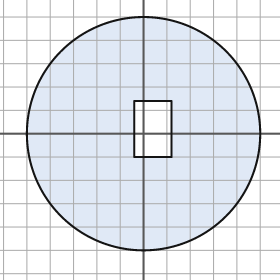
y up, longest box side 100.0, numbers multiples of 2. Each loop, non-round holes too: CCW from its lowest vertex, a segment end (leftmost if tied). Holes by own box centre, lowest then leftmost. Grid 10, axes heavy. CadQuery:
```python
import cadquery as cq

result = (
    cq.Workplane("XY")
    .moveTo(0.0, 0.0)
    .circle(50.0)
    .moveTo(-4.0, -10.0)
    .lineTo(12.0, -10.0)
    .lineTo(12.0, 14.0)
    .lineTo(-4.0, 14.0)
    .close()
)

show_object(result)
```